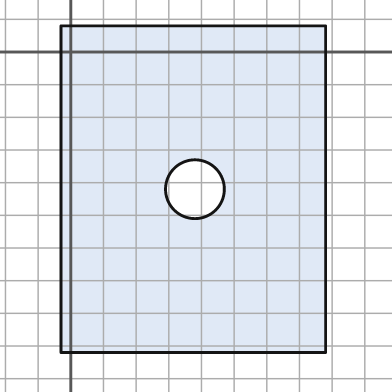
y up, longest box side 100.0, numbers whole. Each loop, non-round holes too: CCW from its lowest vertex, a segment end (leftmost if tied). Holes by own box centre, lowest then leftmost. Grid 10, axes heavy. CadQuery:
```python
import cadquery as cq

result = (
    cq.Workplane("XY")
    .moveTo(-3.0, -92.0)
    .lineTo(78.0, -92.0)
    .lineTo(78.0, 8.0)
    .lineTo(-3.0, 8.0)
    .close()
    .moveTo(38.0, -42.0)
    .circle(9.0)
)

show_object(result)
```